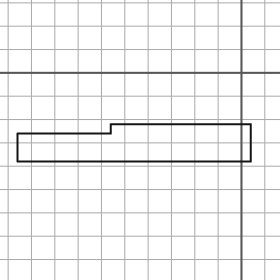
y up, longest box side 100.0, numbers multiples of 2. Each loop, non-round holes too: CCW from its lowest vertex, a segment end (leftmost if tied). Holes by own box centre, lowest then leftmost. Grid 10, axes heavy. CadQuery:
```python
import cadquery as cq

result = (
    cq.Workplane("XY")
    .moveTo(-96.0, -38.0)
    .lineTo(4.0, -38.0)
    .lineTo(4.0, -22.0)
    .lineTo(-56.0, -22.0)
    .lineTo(-56.0, -26.0)
    .lineTo(-96.0, -26.0)
    .close()
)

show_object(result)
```